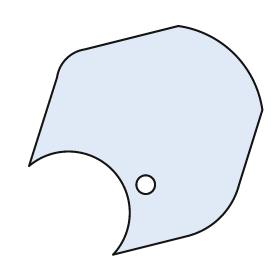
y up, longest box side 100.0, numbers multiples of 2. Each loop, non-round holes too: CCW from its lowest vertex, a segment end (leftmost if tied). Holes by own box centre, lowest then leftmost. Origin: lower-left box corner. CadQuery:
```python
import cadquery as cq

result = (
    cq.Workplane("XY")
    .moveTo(36.0, 0.0)
    .lineTo(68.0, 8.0)
    .threePointArc((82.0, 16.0), (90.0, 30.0))
    .lineTo(100.0, 62.0)
    .threePointArc((88.0, 86.0), (64.0, 98.0))
    .lineTo(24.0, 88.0)
    .threePointArc((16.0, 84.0), (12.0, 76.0))
    .lineTo(0.0, 38.0)
    .threePointArc((36.0, 36.0), (36.0, 0.0))
    .close()
    .moveTo(50.0, 30.0)
    .circle(4.0)
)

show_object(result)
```